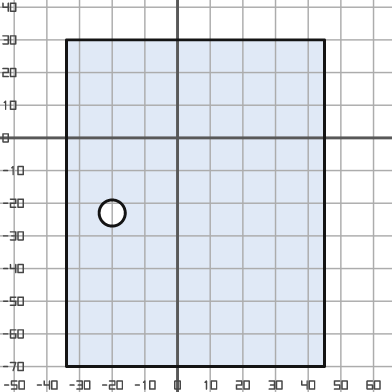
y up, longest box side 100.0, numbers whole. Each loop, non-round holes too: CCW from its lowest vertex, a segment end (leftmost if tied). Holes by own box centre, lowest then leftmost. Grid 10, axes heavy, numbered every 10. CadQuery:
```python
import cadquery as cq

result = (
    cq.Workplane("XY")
    .moveTo(-34.0, -70.0)
    .lineTo(45.0, -70.0)
    .lineTo(45.0, 30.0)
    .lineTo(-34.0, 30.0)
    .close()
    .moveTo(-20.0, -23.0)
    .circle(4.0)
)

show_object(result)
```